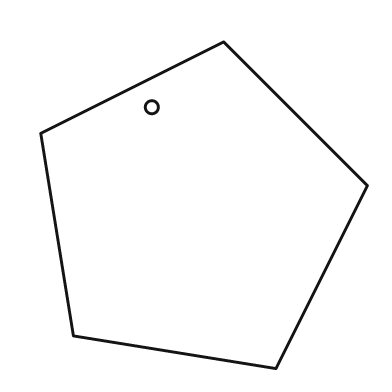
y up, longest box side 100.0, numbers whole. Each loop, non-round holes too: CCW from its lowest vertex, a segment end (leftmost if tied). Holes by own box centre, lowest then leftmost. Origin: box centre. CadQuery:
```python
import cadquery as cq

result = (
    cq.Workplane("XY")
    .moveTo(22.0, -50.0)
    .lineTo(50.0, 6.0)
    .lineTo(6.0, 50.0)
    .lineTo(-50.0, 22.0)
    .lineTo(-40.0, -40.0)
    .close()
    .moveTo(-16.0, 30.0)
    .circle(2.0)
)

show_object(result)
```